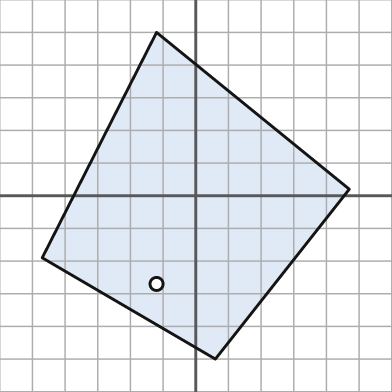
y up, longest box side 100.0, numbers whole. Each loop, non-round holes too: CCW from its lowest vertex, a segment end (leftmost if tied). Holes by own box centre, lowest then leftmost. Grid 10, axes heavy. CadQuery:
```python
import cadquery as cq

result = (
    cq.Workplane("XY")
    .moveTo(6.0, -50.0)
    .lineTo(47.0, 2.0)
    .lineTo(-12.0, 50.0)
    .lineTo(-47.0, -19.0)
    .close()
    .moveTo(-12.0, -27.0)
    .circle(2.0)
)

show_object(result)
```